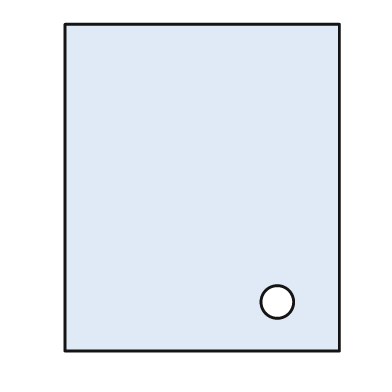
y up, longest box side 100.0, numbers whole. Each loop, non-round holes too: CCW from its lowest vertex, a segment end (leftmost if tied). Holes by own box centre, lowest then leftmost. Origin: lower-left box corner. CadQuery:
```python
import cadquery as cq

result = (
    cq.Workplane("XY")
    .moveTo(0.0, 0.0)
    .lineTo(84.0, 0.0)
    .lineTo(84.0, 100.0)
    .lineTo(0.0, 100.0)
    .close()
    .moveTo(65.0, 15.0)
    .circle(5.0)
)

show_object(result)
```